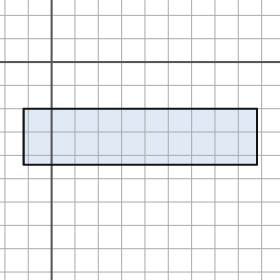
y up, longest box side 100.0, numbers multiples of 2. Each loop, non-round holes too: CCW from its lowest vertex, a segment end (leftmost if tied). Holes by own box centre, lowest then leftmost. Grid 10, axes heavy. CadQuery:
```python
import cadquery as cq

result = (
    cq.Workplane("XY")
    .moveTo(-12.0, -44.0)
    .lineTo(88.0, -44.0)
    .lineTo(88.0, -20.0)
    .lineTo(-12.0, -20.0)
    .close()
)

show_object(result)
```